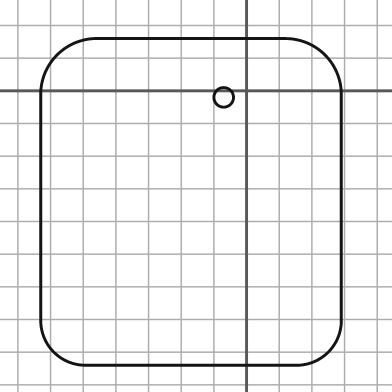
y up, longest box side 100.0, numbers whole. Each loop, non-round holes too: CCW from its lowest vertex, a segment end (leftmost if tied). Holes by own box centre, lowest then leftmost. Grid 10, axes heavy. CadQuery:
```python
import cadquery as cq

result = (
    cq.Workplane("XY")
    .moveTo(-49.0, -84.0)
    .lineTo(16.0, -84.0)
    .threePointArc((25.0, -80.0), (29.0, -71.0))
    .lineTo(29.0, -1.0)
    .threePointArc((24.0, 11.0), (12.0, 16.0))
    .lineTo(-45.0, 16.0)
    .threePointArc((-58.0, 11.0), (-63.0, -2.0))
    .lineTo(-63.0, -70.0)
    .threePointArc((-59.0, -80.0), (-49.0, -84.0))
    .close()
    .moveTo(-7.0, -2.0)
    .circle(3.0)
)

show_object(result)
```